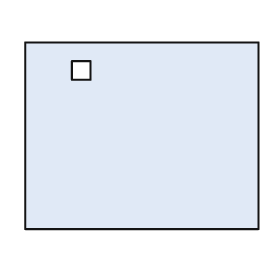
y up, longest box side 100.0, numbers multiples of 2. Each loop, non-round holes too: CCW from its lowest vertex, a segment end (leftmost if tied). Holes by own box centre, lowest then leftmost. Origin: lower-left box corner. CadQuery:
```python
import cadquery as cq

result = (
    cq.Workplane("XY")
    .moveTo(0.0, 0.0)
    .lineTo(100.0, 0.0)
    .lineTo(100.0, 80.0)
    .lineTo(0.0, 80.0)
    .close()
    .moveTo(20.0, 64.0)
    .lineTo(28.0, 64.0)
    .lineTo(28.0, 72.0)
    .lineTo(20.0, 72.0)
    .close()
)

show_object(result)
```